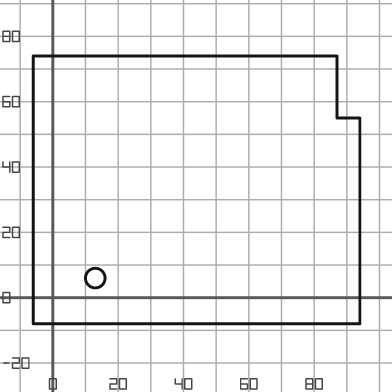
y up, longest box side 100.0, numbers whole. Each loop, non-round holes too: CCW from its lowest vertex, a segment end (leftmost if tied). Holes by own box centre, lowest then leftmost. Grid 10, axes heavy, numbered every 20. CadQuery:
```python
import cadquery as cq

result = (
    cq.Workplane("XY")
    .moveTo(-6.0, -8.0)
    .lineTo(94.0, -8.0)
    .lineTo(94.0, 55.0)
    .lineTo(87.0, 55.0)
    .lineTo(87.0, 74.0)
    .lineTo(-6.0, 74.0)
    .close()
    .moveTo(13.0, 6.0)
    .circle(3.0)
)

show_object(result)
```